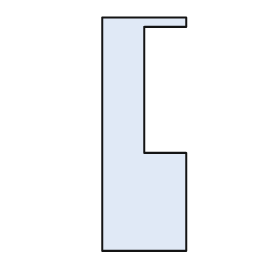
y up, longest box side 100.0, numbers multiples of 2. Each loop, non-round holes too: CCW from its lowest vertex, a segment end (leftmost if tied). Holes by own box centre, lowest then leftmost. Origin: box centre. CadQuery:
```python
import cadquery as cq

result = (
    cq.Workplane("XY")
    .moveTo(-18.0, -50.0)
    .lineTo(18.0, -50.0)
    .lineTo(18.0, -8.0)
    .lineTo(0.0, -8.0)
    .lineTo(0.0, 46.0)
    .lineTo(18.0, 46.0)
    .lineTo(18.0, 50.0)
    .lineTo(-18.0, 50.0)
    .close()
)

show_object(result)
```